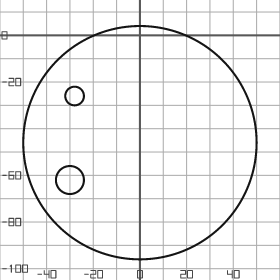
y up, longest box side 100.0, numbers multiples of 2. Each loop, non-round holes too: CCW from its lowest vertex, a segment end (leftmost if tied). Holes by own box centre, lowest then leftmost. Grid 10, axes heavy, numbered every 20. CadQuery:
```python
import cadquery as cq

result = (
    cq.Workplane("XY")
    .moveTo(0.0, -46.0)
    .circle(50.0)
    .moveTo(-30.0, -62.0)
    .circle(6.0)
    .moveTo(-28.0, -26.0)
    .circle(4.0)
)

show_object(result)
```